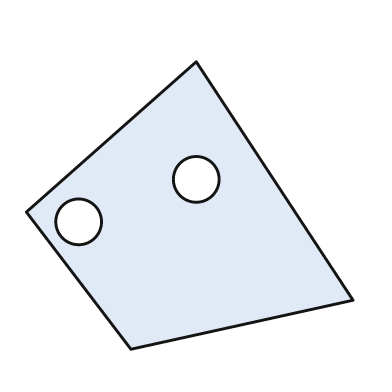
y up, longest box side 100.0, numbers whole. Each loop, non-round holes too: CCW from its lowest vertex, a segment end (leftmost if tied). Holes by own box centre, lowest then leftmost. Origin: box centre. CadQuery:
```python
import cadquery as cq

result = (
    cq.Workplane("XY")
    .moveTo(-18.0, -44.0)
    .lineTo(50.0, -29.0)
    .lineTo(2.0, 44.0)
    .lineTo(-50.0, -2.0)
    .close()
    .moveTo(-34.0, -5.0)
    .circle(7.0)
    .moveTo(2.0, 8.0)
    .circle(7.0)
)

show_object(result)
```